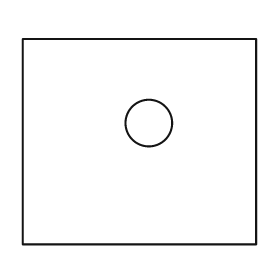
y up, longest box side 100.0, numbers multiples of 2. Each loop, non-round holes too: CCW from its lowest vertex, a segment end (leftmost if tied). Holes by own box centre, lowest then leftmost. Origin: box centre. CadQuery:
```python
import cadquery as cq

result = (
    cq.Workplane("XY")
    .moveTo(-50.0, -44.0)
    .lineTo(50.0, -44.0)
    .lineTo(50.0, 44.0)
    .lineTo(-50.0, 44.0)
    .close()
    .moveTo(4.0, 8.0)
    .circle(10.0)
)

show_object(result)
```